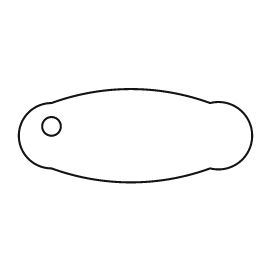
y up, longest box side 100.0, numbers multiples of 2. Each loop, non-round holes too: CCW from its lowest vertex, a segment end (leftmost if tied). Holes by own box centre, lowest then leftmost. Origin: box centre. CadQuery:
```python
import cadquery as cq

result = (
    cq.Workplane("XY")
    .moveTo(-36.0, -14.0)
    .threePointArc((-2.0, -20.0), (32.0, -14.0))
    .threePointArc((50.0, 0.0), (32.0, 14.0))
    .threePointArc((-2.0, 20.0), (-36.0, 14.0))
    .threePointArc((-50.0, 0.0), (-36.0, -14.0))
    .close()
    .moveTo(-36.0, 4.0)
    .circle(4.0)
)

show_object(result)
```